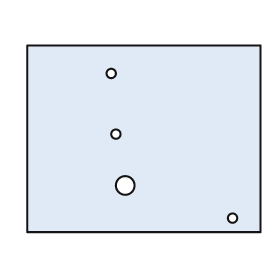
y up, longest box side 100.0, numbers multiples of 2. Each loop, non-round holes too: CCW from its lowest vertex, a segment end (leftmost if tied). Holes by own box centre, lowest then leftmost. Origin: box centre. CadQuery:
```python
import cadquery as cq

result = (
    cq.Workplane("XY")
    .moveTo(-50.0, -40.0)
    .lineTo(50.0, -40.0)
    .lineTo(50.0, 40.0)
    .lineTo(-50.0, 40.0)
    .close()
    .moveTo(38.0, -34.0)
    .circle(2.0)
    .moveTo(-8.0, -20.0)
    .circle(4.0)
    .moveTo(-12.0, 2.0)
    .circle(2.0)
    .moveTo(-14.0, 28.0)
    .circle(2.0)
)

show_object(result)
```